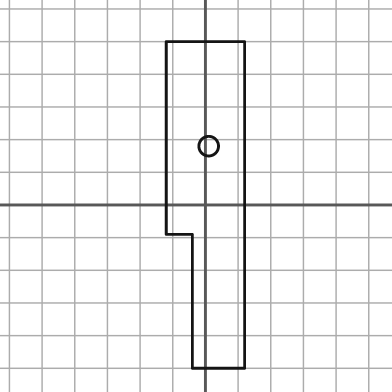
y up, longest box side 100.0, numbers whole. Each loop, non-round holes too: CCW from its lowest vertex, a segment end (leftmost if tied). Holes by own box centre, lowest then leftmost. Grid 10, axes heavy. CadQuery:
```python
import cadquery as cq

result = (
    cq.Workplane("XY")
    .moveTo(-4.0, -50.0)
    .lineTo(12.0, -50.0)
    .lineTo(12.0, 50.0)
    .lineTo(-12.0, 50.0)
    .lineTo(-12.0, -9.0)
    .lineTo(-4.0, -9.0)
    .close()
    .moveTo(1.0, 18.0)
    .circle(3.0)
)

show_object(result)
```